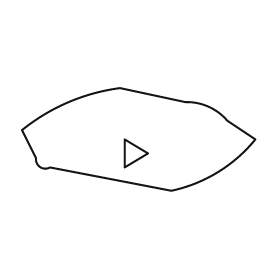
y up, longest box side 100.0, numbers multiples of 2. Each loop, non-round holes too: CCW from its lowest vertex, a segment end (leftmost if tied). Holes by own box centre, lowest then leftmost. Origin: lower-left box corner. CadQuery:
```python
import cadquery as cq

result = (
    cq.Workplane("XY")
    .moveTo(64.0, 0.0)
    .threePointArc((84.0, 8.0), (100.0, 22.0))
    .lineTo(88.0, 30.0)
    .threePointArc((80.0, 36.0), (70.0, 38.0))
    .lineTo(42.0, 44.0)
    .threePointArc((20.0, 38.0), (0.0, 26.0))
    .lineTo(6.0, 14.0)
    .threePointArc((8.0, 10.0), (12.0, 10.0))
    .close()
    .moveTo(44.0, 10.0)
    .lineTo(54.0, 16.0)
    .lineTo(44.0, 22.0)
    .close()
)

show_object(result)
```